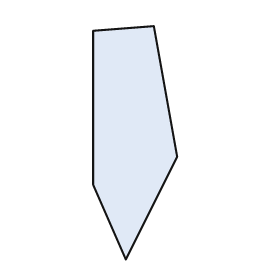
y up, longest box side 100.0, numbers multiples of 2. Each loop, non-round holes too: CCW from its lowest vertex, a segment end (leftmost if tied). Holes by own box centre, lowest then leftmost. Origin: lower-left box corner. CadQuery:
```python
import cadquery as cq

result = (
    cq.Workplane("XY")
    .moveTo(14.0, 0.0)
    .lineTo(36.0, 44.0)
    .lineTo(26.0, 100.0)
    .lineTo(0.0, 98.0)
    .lineTo(0.0, 32.0)
    .close()
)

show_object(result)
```